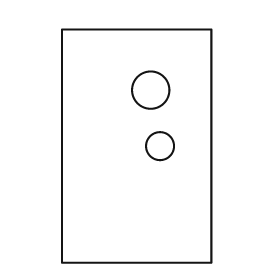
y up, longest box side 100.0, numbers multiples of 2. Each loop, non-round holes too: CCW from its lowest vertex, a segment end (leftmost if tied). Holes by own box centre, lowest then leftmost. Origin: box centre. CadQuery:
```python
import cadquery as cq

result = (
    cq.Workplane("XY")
    .moveTo(-32.0, -50.0)
    .lineTo(32.0, -50.0)
    .lineTo(32.0, 50.0)
    .lineTo(-32.0, 50.0)
    .close()
    .moveTo(10.0, 0.0)
    .circle(6.0)
    .moveTo(6.0, 24.0)
    .circle(8.0)
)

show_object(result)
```